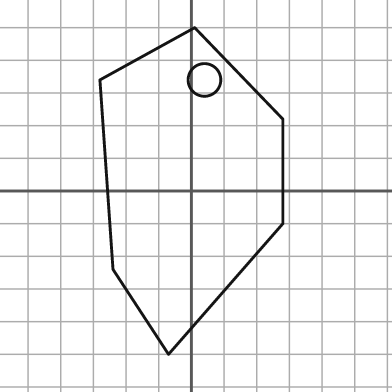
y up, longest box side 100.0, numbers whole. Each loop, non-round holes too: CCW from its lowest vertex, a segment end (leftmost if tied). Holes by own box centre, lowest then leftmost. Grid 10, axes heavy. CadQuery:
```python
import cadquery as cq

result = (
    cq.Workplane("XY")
    .moveTo(-7.0, -50.0)
    .lineTo(28.0, -10.0)
    .lineTo(28.0, 22.0)
    .lineTo(1.0, 50.0)
    .lineTo(-28.0, 34.0)
    .lineTo(-24.0, -24.0)
    .close()
    .moveTo(4.0, 34.0)
    .circle(5.0)
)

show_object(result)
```